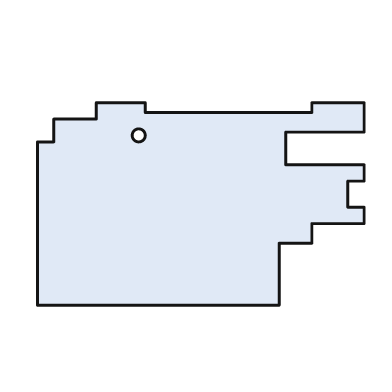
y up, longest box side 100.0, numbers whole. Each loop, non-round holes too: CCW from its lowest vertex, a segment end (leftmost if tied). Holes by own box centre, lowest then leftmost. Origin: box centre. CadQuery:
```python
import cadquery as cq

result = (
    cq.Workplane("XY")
    .moveTo(-50.0, -31.0)
    .lineTo(24.0, -31.0)
    .lineTo(24.0, -12.0)
    .lineTo(34.0, -12.0)
    .lineTo(34.0, -6.0)
    .lineTo(50.0, -6.0)
    .lineTo(50.0, -1.0)
    .lineTo(45.0, -1.0)
    .lineTo(45.0, 7.0)
    .lineTo(50.0, 7.0)
    .lineTo(50.0, 12.0)
    .lineTo(26.0, 12.0)
    .lineTo(26.0, 22.0)
    .lineTo(50.0, 22.0)
    .lineTo(50.0, 31.0)
    .lineTo(34.0, 31.0)
    .lineTo(34.0, 28.0)
    .lineTo(-17.0, 28.0)
    .lineTo(-17.0, 31.0)
    .lineTo(-32.0, 31.0)
    .lineTo(-32.0, 26.0)
    .lineTo(-45.0, 26.0)
    .lineTo(-45.0, 19.0)
    .lineTo(-50.0, 19.0)
    .close()
    .moveTo(-19.0, 21.0)
    .circle(2.0)
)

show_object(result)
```